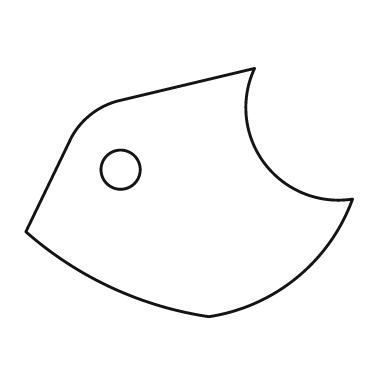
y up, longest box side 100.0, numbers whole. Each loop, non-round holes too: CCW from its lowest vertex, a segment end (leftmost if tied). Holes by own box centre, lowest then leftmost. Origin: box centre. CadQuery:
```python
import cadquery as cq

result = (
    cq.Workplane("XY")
    .moveTo(6.0, -38.0)
    .threePointArc((33.0, -26.0), (50.0, -2.0))
    .threePointArc((23.0, 9.0), (20.0, 38.0))
    .lineTo(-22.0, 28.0)
    .threePointArc((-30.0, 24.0), (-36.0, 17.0))
    .lineTo(-50.0, -12.0)
    .threePointArc((-24.0, -29.0), (6.0, -38.0))
    .close()
    .moveTo(-21.0, 7.0)
    .circle(6.0)
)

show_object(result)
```